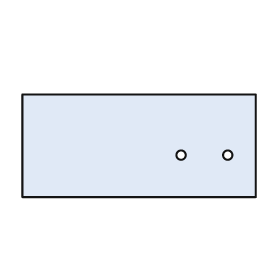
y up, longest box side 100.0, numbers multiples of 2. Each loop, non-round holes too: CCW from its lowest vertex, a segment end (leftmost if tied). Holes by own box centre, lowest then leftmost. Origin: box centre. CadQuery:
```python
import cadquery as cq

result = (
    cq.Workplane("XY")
    .moveTo(-50.0, -22.0)
    .lineTo(50.0, -22.0)
    .lineTo(50.0, 22.0)
    .lineTo(-50.0, 22.0)
    .close()
    .moveTo(18.0, -4.0)
    .circle(2.0)
    .moveTo(38.0, -4.0)
    .circle(2.0)
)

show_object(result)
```